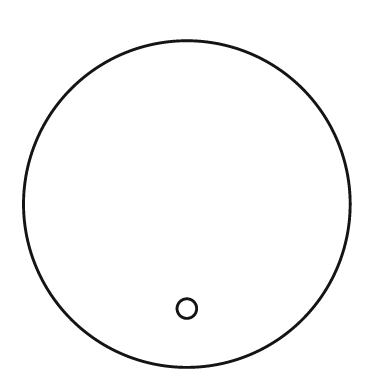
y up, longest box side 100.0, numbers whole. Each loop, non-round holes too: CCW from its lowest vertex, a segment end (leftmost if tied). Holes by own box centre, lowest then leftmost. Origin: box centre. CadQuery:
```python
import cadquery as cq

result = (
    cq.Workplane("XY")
    .moveTo(0.0, 0.0)
    .circle(50.0)
    .moveTo(0.0, -32.0)
    .circle(3.0)
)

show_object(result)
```